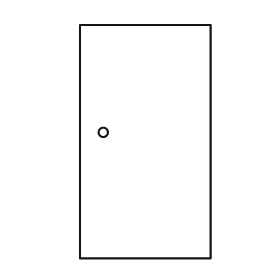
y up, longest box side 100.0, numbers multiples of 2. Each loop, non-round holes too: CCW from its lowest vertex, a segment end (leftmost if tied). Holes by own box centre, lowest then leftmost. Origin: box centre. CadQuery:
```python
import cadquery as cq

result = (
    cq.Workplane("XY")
    .moveTo(-28.0, -50.0)
    .lineTo(28.0, -50.0)
    .lineTo(28.0, 50.0)
    .lineTo(-28.0, 50.0)
    .close()
    .moveTo(-18.0, 4.0)
    .circle(2.0)
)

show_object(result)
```